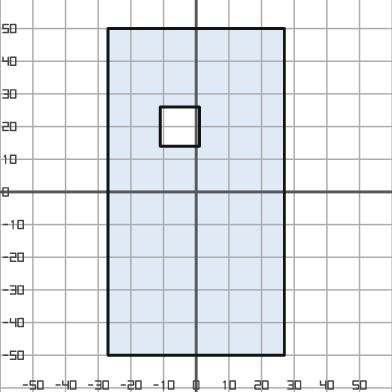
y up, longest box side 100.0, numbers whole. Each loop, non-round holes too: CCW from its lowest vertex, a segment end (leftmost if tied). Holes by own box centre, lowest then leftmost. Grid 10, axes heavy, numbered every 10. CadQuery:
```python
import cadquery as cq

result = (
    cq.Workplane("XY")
    .moveTo(-27.0, -50.0)
    .lineTo(27.0, -50.0)
    .lineTo(27.0, 50.0)
    .lineTo(-27.0, 50.0)
    .close()
    .moveTo(-11.0, 14.0)
    .lineTo(1.0, 14.0)
    .lineTo(1.0, 26.0)
    .lineTo(-11.0, 26.0)
    .close()
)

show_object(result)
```